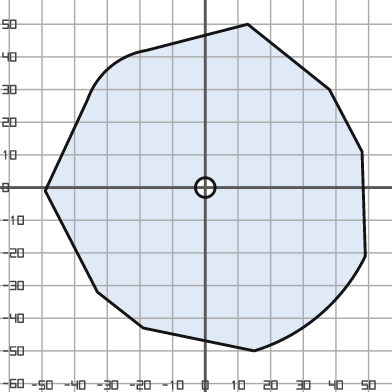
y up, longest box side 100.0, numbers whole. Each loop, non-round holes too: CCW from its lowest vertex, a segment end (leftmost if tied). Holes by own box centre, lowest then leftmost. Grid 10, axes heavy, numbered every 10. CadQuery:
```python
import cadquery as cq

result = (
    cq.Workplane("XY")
    .moveTo(15.0, -50.0)
    .threePointArc((35.0, -39.0), (49.0, -21.0))
    .lineTo(48.0, 11.0)
    .lineTo(38.0, 30.0)
    .lineTo(13.0, 50.0)
    .lineTo(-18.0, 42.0)
    .threePointArc((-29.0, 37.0), (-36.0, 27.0))
    .lineTo(-49.0, -1.0)
    .lineTo(-33.0, -32.0)
    .lineTo(-19.0, -43.0)
    .close()
    .moveTo(0.0, 0.0)
    .circle(3.0)
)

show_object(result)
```